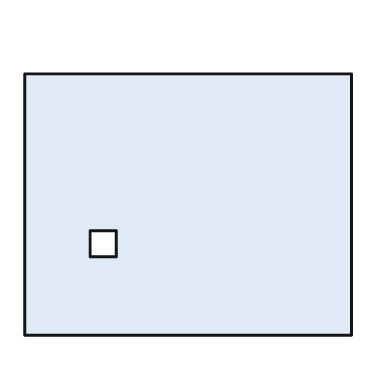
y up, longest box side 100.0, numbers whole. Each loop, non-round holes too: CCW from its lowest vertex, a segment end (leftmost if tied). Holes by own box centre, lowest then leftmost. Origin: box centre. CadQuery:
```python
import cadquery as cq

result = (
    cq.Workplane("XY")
    .moveTo(-50.0, -40.0)
    .lineTo(50.0, -40.0)
    .lineTo(50.0, 40.0)
    .lineTo(-50.0, 40.0)
    .close()
    .moveTo(-30.0, -16.0)
    .lineTo(-22.0, -16.0)
    .lineTo(-22.0, -8.0)
    .lineTo(-30.0, -8.0)
    .close()
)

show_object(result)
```